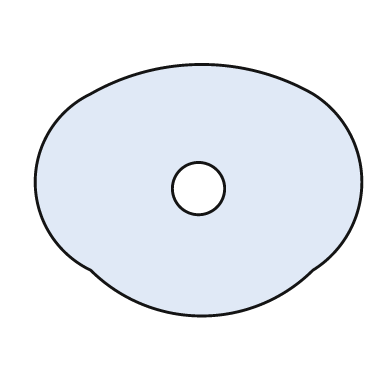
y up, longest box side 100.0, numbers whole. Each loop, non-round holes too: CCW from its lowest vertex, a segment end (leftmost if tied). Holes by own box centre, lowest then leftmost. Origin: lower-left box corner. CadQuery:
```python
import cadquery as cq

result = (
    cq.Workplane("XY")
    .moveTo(17.0, 14.0)
    .threePointArc((51.0, 0.0), (85.0, 14.0))
    .threePointArc((100.0, 41.0), (85.0, 68.0))
    .threePointArc((51.0, 77.0), (17.0, 68.0))
    .threePointArc((0.0, 41.0), (17.0, 14.0))
    .close()
    .moveTo(50.0, 39.0)
    .circle(8.0)
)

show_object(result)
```